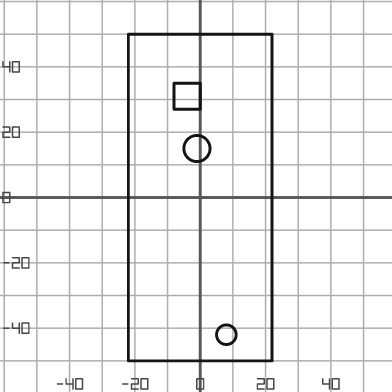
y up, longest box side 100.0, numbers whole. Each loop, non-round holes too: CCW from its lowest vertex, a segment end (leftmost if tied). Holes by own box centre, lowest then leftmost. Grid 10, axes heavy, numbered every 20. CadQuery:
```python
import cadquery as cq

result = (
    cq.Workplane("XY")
    .moveTo(-22.0, -50.0)
    .lineTo(22.0, -50.0)
    .lineTo(22.0, 50.0)
    .lineTo(-22.0, 50.0)
    .close()
    .moveTo(8.0, -42.0)
    .circle(3.0)
    .moveTo(-1.0, 15.0)
    .circle(4.0)
    .moveTo(-8.0, 27.0)
    .lineTo(0.0, 27.0)
    .lineTo(0.0, 35.0)
    .lineTo(-8.0, 35.0)
    .close()
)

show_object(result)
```